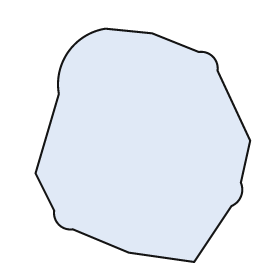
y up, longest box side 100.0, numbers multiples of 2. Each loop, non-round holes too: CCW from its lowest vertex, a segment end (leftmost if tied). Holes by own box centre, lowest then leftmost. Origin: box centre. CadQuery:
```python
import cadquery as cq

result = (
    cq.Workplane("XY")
    .moveTo(22.0, -50.0)
    .lineTo(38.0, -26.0)
    .threePointArc((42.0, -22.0), (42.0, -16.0))
    .lineTo(46.0, 2.0)
    .lineTo(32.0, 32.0)
    .threePointArc((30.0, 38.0), (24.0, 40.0))
    .lineTo(4.0, 48.0)
    .lineTo(-16.0, 50.0)
    .threePointArc((-32.0, 40.0), (-36.0, 22.0))
    .lineTo(-46.0, -12.0)
    .lineTo(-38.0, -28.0)
    .threePointArc((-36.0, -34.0), (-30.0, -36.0))
    .lineTo(-6.0, -46.0)
    .close()
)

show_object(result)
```